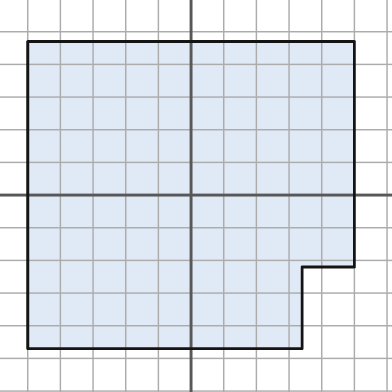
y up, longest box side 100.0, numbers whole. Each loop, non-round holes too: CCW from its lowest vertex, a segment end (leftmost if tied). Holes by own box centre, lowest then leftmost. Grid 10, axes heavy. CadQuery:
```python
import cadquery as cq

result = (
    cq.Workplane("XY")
    .moveTo(-50.0, -47.0)
    .lineTo(34.0, -47.0)
    .lineTo(34.0, -22.0)
    .lineTo(50.0, -22.0)
    .lineTo(50.0, 47.0)
    .lineTo(-50.0, 47.0)
    .close()
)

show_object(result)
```